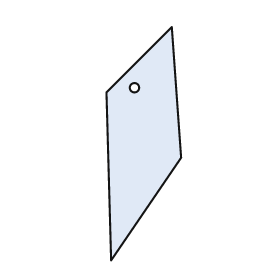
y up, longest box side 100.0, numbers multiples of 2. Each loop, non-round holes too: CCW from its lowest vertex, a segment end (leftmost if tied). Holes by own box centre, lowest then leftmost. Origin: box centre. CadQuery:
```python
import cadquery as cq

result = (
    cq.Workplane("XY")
    .moveTo(-14.0, -50.0)
    .lineTo(16.0, -6.0)
    .lineTo(12.0, 50.0)
    .lineTo(-16.0, 22.0)
    .close()
    .moveTo(-4.0, 24.0)
    .circle(2.0)
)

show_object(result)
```